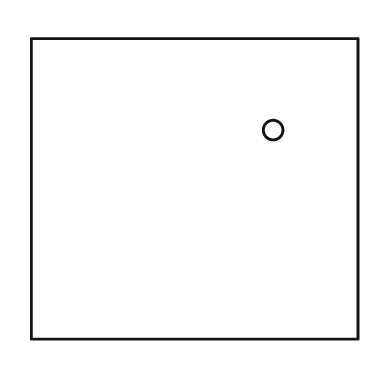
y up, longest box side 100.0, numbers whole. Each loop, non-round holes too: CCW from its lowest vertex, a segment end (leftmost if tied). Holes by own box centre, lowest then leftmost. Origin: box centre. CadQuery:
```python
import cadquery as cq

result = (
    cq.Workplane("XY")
    .moveTo(-50.0, -46.0)
    .lineTo(50.0, -46.0)
    .lineTo(50.0, 46.0)
    .lineTo(-50.0, 46.0)
    .close()
    .moveTo(24.0, 18.0)
    .circle(3.0)
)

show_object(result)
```